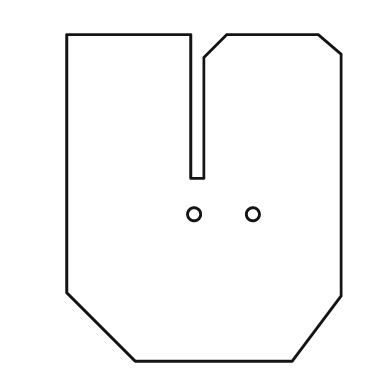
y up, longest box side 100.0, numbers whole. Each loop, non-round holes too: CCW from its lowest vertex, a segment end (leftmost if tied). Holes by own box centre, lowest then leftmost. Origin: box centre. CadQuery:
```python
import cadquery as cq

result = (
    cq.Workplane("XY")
    .moveTo(-21.0, -50.0)
    .lineTo(27.0, -50.0)
    .lineTo(42.0, -30.0)
    .lineTo(42.0, 44.0)
    .lineTo(35.0, 50.0)
    .lineTo(7.0, 50.0)
    .lineTo(0.0, 43.0)
    .lineTo(0.0, 6.0)
    .lineTo(-4.0, 6.0)
    .lineTo(-4.0, 50.0)
    .lineTo(-42.0, 50.0)
    .lineTo(-42.0, -29.0)
    .close()
    .moveTo(-3.0, -5.0)
    .circle(2.0)
    .moveTo(15.0, -5.0)
    .circle(2.0)
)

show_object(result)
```